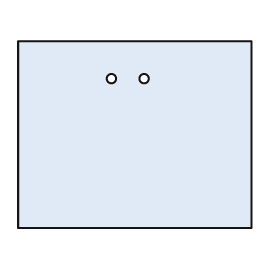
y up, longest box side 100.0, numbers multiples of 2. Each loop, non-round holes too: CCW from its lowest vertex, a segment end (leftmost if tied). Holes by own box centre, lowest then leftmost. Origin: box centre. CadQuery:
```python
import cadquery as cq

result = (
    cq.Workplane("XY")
    .moveTo(-50.0, -40.0)
    .lineTo(50.0, -40.0)
    .lineTo(50.0, 40.0)
    .lineTo(-50.0, 40.0)
    .close()
    .moveTo(-10.0, 24.0)
    .circle(2.0)
    .moveTo(4.0, 24.0)
    .circle(2.0)
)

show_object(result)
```